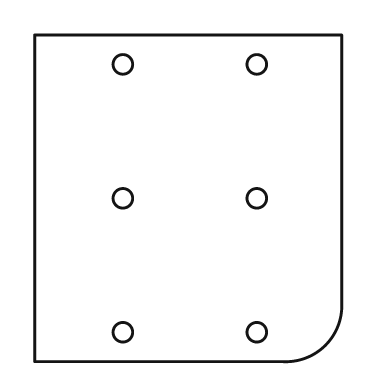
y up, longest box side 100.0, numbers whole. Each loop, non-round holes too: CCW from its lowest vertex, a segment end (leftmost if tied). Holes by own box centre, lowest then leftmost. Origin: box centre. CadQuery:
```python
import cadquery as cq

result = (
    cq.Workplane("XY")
    .moveTo(-47.0, -50.0)
    .lineTo(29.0, -50.0)
    .threePointArc((42.0, -45.0), (47.0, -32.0))
    .lineTo(47.0, 50.0)
    .lineTo(-47.0, 50.0)
    .close()
    .moveTo(-20.0, -41.0)
    .circle(3.0)
    .moveTo(21.0, -41.0)
    .circle(3.0)
    .moveTo(-20.0, 0.0)
    .circle(3.0)
    .moveTo(21.0, 0.0)
    .circle(3.0)
    .moveTo(-20.0, 41.0)
    .circle(3.0)
    .moveTo(21.0, 41.0)
    .circle(3.0)
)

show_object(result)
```